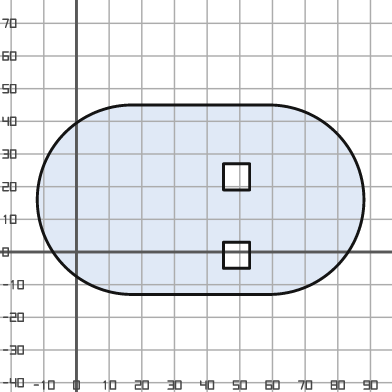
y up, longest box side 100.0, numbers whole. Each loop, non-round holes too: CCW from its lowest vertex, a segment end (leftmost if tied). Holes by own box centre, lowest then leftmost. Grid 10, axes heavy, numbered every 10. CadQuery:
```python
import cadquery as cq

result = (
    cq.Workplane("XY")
    .moveTo(17.0, -13.0)
    .lineTo(59.0, -13.0)
    .threePointArc((88.0, 16.0), (59.0, 45.0))
    .lineTo(17.0, 45.0)
    .threePointArc((-12.0, 16.0), (17.0, -13.0))
    .close()
    .moveTo(45.0, -5.0)
    .lineTo(53.0, -5.0)
    .lineTo(53.0, 3.0)
    .lineTo(45.0, 3.0)
    .close()
    .moveTo(45.0, 19.0)
    .lineTo(53.0, 19.0)
    .lineTo(53.0, 27.0)
    .lineTo(45.0, 27.0)
    .close()
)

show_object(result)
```